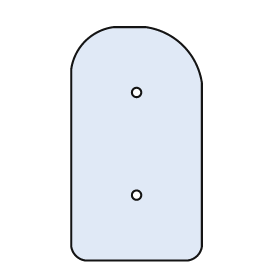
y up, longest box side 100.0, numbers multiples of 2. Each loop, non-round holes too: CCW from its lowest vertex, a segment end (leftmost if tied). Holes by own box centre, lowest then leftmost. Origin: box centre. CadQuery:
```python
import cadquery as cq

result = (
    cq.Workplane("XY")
    .moveTo(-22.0, -50.0)
    .lineTo(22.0, -50.0)
    .threePointArc((26.0, -48.0), (28.0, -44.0))
    .lineTo(28.0, 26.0)
    .threePointArc((20.0, 42.0), (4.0, 50.0))
    .lineTo(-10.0, 50.0)
    .threePointArc((-22.0, 44.0), (-28.0, 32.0))
    .lineTo(-28.0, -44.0)
    .threePointArc((-26.0, -48.0), (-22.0, -50.0))
    .close()
    .moveTo(0.0, -22.0)
    .circle(2.0)
    .moveTo(0.0, 22.0)
    .circle(2.0)
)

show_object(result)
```